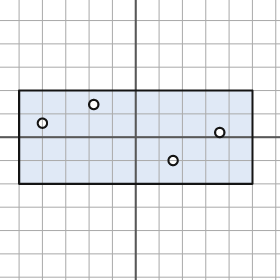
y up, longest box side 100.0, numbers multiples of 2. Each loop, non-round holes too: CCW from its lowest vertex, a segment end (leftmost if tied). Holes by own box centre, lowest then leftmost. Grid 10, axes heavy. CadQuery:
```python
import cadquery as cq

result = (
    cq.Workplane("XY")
    .moveTo(-50.0, -20.0)
    .lineTo(50.0, -20.0)
    .lineTo(50.0, 20.0)
    .lineTo(-50.0, 20.0)
    .close()
    .moveTo(16.0, -10.0)
    .circle(2.0)
    .moveTo(36.0, 2.0)
    .circle(2.0)
    .moveTo(-40.0, 6.0)
    .circle(2.0)
    .moveTo(-18.0, 14.0)
    .circle(2.0)
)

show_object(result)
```